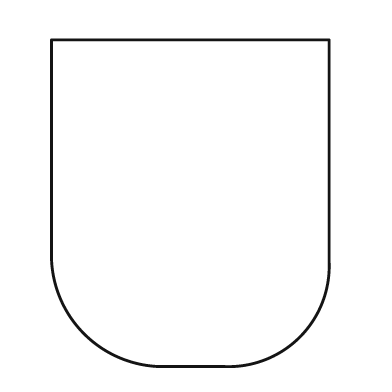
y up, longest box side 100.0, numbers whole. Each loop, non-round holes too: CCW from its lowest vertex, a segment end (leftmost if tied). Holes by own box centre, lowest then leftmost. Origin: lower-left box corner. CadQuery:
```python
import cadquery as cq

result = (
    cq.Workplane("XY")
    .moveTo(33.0, 0.0)
    .lineTo(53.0, 0.0)
    .threePointArc((76.0, 9.0), (85.0, 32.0))
    .lineTo(85.0, 100.0)
    .lineTo(0.0, 100.0)
    .lineTo(0.0, 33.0)
    .threePointArc((10.0, 10.0), (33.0, 0.0))
    .close()
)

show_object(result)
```